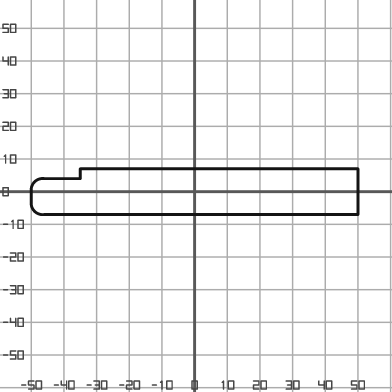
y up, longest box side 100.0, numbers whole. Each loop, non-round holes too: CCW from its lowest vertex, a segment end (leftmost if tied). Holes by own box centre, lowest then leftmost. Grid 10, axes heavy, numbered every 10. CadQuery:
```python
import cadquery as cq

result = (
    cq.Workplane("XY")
    .moveTo(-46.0, -7.0)
    .lineTo(50.0, -7.0)
    .lineTo(50.0, 7.0)
    .lineTo(-35.0, 7.0)
    .lineTo(-35.0, 4.0)
    .lineTo(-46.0, 4.0)
    .threePointArc((-49.0, 3.0), (-50.0, 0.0))
    .lineTo(-50.0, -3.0)
    .threePointArc((-49.0, -6.0), (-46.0, -7.0))
    .close()
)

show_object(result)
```